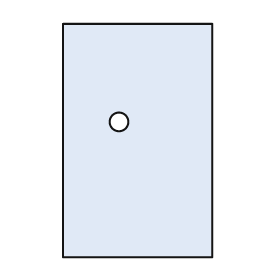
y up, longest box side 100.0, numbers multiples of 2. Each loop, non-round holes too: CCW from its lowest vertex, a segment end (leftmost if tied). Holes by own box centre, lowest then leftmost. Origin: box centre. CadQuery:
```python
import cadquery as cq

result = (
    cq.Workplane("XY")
    .moveTo(-32.0, -50.0)
    .lineTo(32.0, -50.0)
    .lineTo(32.0, 50.0)
    .lineTo(-32.0, 50.0)
    .close()
    .moveTo(-8.0, 8.0)
    .circle(4.0)
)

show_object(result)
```